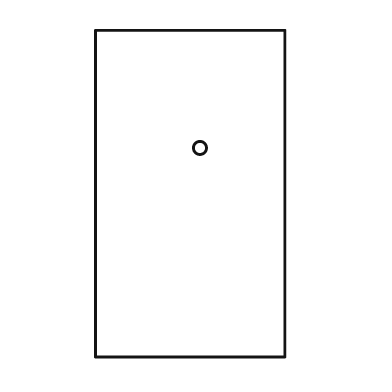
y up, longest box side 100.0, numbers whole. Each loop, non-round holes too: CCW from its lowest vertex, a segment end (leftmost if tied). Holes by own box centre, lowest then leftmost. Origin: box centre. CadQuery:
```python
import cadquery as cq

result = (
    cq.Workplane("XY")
    .moveTo(-29.0, -50.0)
    .lineTo(29.0, -50.0)
    .lineTo(29.0, 50.0)
    .lineTo(-29.0, 50.0)
    .close()
    .moveTo(3.0, 14.0)
    .circle(2.0)
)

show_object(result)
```